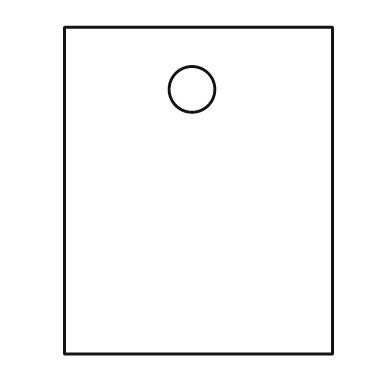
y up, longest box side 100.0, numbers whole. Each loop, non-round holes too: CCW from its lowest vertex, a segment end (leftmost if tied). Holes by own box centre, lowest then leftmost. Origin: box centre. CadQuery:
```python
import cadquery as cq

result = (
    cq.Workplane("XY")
    .moveTo(-41.0, -50.0)
    .lineTo(41.0, -50.0)
    .lineTo(41.0, 50.0)
    .lineTo(-41.0, 50.0)
    .close()
    .moveTo(-2.0, 31.0)
    .circle(7.0)
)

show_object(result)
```